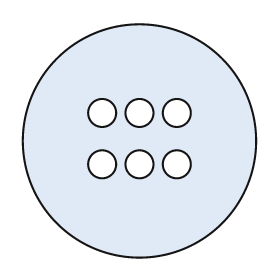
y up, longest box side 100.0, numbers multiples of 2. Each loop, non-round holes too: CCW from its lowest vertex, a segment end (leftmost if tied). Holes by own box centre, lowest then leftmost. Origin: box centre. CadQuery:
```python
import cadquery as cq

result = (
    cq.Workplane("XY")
    .moveTo(0.0, 0.0)
    .circle(50.0)
    .moveTo(-16.0, -10.0)
    .circle(6.0)
    .moveTo(0.0, -10.0)
    .circle(6.0)
    .moveTo(16.0, -10.0)
    .circle(6.0)
    .moveTo(-16.0, 12.0)
    .circle(6.0)
    .moveTo(0.0, 12.0)
    .circle(6.0)
    .moveTo(16.0, 12.0)
    .circle(6.0)
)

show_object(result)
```